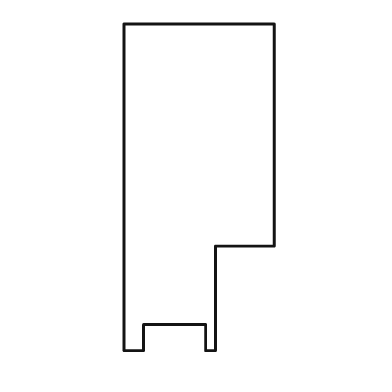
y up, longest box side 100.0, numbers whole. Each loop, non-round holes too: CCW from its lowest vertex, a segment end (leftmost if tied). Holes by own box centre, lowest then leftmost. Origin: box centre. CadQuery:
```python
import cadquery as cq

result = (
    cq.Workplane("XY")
    .moveTo(-23.0, -50.0)
    .lineTo(-17.0, -50.0)
    .lineTo(-17.0, -42.0)
    .lineTo(2.0, -42.0)
    .lineTo(2.0, -50.0)
    .lineTo(5.0, -50.0)
    .lineTo(5.0, -18.0)
    .lineTo(23.0, -18.0)
    .lineTo(23.0, 50.0)
    .lineTo(-23.0, 50.0)
    .close()
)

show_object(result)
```